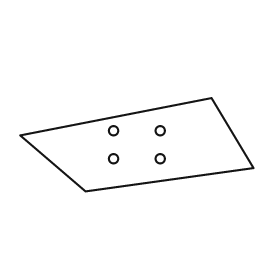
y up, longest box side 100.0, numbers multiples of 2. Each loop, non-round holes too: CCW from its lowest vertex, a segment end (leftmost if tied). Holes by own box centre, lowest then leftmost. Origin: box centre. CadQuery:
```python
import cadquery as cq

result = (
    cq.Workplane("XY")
    .moveTo(-22.0, -20.0)
    .lineTo(50.0, -10.0)
    .lineTo(32.0, 20.0)
    .lineTo(-50.0, 4.0)
    .close()
    .moveTo(-10.0, -6.0)
    .circle(2.0)
    .moveTo(10.0, -6.0)
    .circle(2.0)
    .moveTo(-10.0, 6.0)
    .circle(2.0)
    .moveTo(10.0, 6.0)
    .circle(2.0)
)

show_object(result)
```